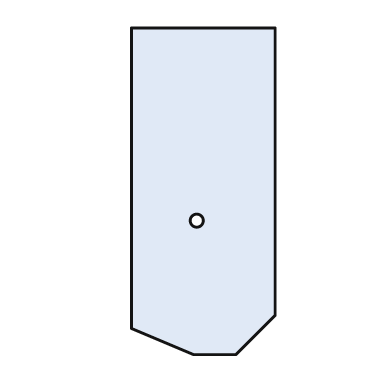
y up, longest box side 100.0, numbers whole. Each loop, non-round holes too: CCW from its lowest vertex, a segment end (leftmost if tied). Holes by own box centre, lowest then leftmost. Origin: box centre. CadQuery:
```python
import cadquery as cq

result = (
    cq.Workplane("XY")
    .moveTo(-3.0, -50.0)
    .lineTo(10.0, -50.0)
    .lineTo(22.0, -38.0)
    .lineTo(22.0, 50.0)
    .lineTo(-22.0, 50.0)
    .lineTo(-22.0, -42.0)
    .close()
    .moveTo(-2.0, -9.0)
    .circle(2.0)
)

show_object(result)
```